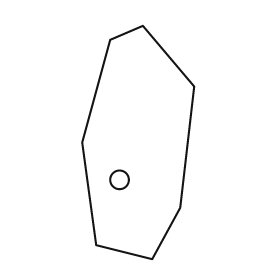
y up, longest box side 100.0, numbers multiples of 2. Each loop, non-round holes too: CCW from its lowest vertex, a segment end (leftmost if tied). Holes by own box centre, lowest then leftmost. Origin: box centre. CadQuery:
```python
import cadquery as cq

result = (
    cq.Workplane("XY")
    .moveTo(6.0, -50.0)
    .lineTo(18.0, -28.0)
    .lineTo(24.0, 24.0)
    .lineTo(2.0, 50.0)
    .lineTo(-12.0, 44.0)
    .lineTo(-24.0, 0.0)
    .lineTo(-18.0, -44.0)
    .close()
    .moveTo(-8.0, -16.0)
    .circle(4.0)
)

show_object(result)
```